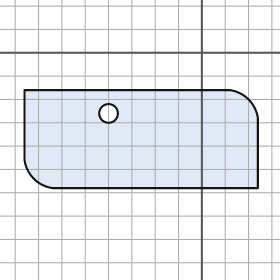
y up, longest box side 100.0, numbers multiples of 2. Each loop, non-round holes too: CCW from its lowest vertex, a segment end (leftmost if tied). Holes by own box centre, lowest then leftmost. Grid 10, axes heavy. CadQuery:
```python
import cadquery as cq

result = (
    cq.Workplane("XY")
    .moveTo(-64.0, -58.0)
    .lineTo(24.0, -58.0)
    .lineTo(24.0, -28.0)
    .threePointArc((20.0, -20.0), (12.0, -16.0))
    .lineTo(-76.0, -16.0)
    .lineTo(-76.0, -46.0)
    .threePointArc((-72.0, -54.0), (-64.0, -58.0))
    .close()
    .moveTo(-40.0, -26.0)
    .circle(4.0)
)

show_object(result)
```